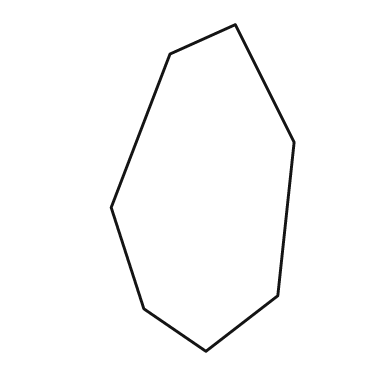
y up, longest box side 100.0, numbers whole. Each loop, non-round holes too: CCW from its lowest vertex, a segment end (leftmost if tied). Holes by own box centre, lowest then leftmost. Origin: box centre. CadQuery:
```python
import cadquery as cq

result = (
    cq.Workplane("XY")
    .moveTo(1.0, -50.0)
    .lineTo(23.0, -33.0)
    .lineTo(28.0, 14.0)
    .lineTo(10.0, 50.0)
    .lineTo(-10.0, 41.0)
    .lineTo(-28.0, -6.0)
    .lineTo(-18.0, -37.0)
    .close()
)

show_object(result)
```